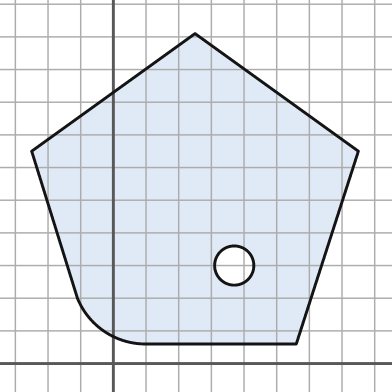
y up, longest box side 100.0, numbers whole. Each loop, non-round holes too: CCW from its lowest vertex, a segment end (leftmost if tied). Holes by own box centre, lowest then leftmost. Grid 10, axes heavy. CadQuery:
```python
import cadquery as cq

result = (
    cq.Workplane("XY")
    .moveTo(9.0, 6.0)
    .lineTo(56.0, 6.0)
    .lineTo(75.0, 65.0)
    .lineTo(25.0, 101.0)
    .lineTo(-25.0, 65.0)
    .lineTo(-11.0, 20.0)
    .threePointArc((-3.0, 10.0), (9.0, 6.0))
    .close()
    .moveTo(37.0, 30.0)
    .circle(6.0)
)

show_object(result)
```